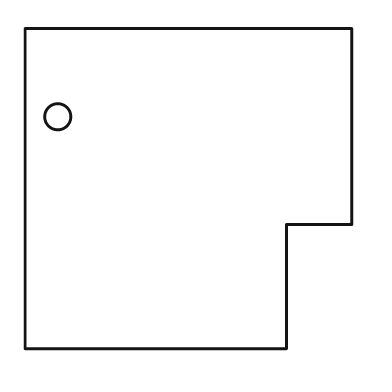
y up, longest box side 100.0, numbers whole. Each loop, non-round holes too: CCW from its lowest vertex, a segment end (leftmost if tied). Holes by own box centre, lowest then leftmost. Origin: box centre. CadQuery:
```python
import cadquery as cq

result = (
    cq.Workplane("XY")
    .moveTo(-50.0, -49.0)
    .lineTo(30.0, -49.0)
    .lineTo(30.0, -11.0)
    .lineTo(50.0, -11.0)
    .lineTo(50.0, 49.0)
    .lineTo(-50.0, 49.0)
    .close()
    .moveTo(-40.0, 22.0)
    .circle(4.0)
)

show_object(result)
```